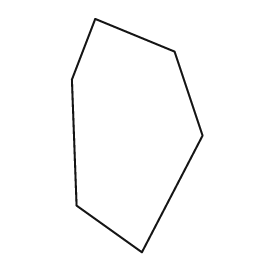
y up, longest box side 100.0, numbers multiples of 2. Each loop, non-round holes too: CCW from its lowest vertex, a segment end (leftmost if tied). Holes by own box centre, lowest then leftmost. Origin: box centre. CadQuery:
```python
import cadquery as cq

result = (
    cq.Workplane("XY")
    .moveTo(2.0, -50.0)
    .lineTo(28.0, 0.0)
    .lineTo(16.0, 36.0)
    .lineTo(-18.0, 50.0)
    .lineTo(-28.0, 24.0)
    .lineTo(-26.0, -30.0)
    .close()
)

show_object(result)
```